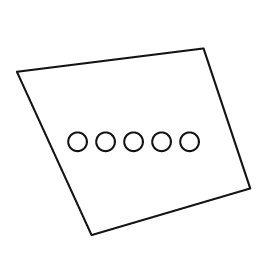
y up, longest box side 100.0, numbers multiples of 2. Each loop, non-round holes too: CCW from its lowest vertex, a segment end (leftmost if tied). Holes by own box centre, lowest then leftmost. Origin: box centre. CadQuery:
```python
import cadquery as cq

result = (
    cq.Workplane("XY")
    .moveTo(-18.0, -40.0)
    .lineTo(50.0, -20.0)
    .lineTo(30.0, 40.0)
    .lineTo(-50.0, 30.0)
    .close()
    .moveTo(-24.0, 0.0)
    .circle(4.0)
    .moveTo(-12.0, 0.0)
    .circle(4.0)
    .moveTo(0.0, 0.0)
    .circle(4.0)
    .moveTo(12.0, 0.0)
    .circle(4.0)
    .moveTo(24.0, 0.0)
    .circle(4.0)
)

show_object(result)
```